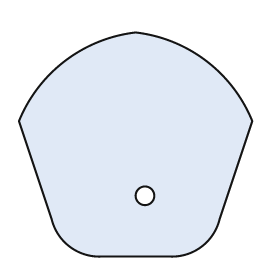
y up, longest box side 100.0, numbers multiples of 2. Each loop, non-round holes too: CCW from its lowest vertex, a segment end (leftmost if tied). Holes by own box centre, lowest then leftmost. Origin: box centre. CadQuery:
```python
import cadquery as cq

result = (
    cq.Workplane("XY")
    .moveTo(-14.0, -48.0)
    .lineTo(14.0, -48.0)
    .threePointArc((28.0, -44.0), (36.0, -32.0))
    .lineTo(50.0, 10.0)
    .threePointArc((30.0, 36.0), (0.0, 48.0))
    .threePointArc((-30.0, 36.0), (-50.0, 10.0))
    .lineTo(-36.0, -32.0)
    .threePointArc((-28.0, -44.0), (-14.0, -48.0))
    .close()
    .moveTo(4.0, -22.0)
    .circle(4.0)
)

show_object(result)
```